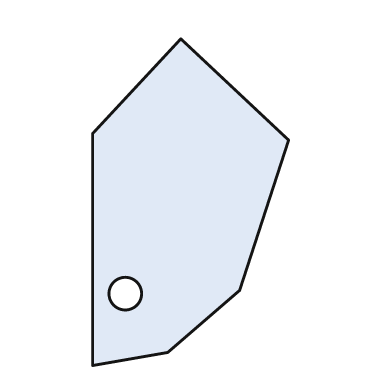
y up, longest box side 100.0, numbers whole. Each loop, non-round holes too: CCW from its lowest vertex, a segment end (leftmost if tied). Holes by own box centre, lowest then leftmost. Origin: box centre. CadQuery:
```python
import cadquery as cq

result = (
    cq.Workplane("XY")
    .moveTo(-30.0, -50.0)
    .lineTo(-7.0, -46.0)
    .lineTo(15.0, -27.0)
    .lineTo(30.0, 19.0)
    .lineTo(-3.0, 50.0)
    .lineTo(-30.0, 21.0)
    .close()
    .moveTo(-20.0, -28.0)
    .circle(5.0)
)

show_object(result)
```